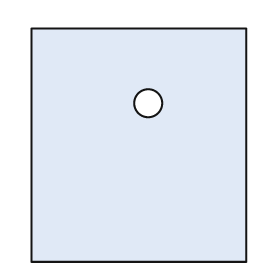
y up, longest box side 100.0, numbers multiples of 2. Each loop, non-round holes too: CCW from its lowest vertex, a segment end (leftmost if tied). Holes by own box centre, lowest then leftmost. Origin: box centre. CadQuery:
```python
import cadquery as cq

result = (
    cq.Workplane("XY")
    .moveTo(-46.0, -50.0)
    .lineTo(46.0, -50.0)
    .lineTo(46.0, 50.0)
    .lineTo(-46.0, 50.0)
    .close()
    .moveTo(4.0, 18.0)
    .circle(6.0)
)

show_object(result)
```